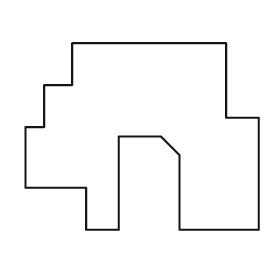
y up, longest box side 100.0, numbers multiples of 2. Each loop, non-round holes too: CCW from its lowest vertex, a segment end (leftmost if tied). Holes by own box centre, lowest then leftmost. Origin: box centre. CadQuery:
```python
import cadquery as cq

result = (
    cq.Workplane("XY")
    .moveTo(-24.0, -40.0)
    .lineTo(-10.0, -40.0)
    .lineTo(-10.0, 0.0)
    .lineTo(8.0, 0.0)
    .lineTo(16.0, -8.0)
    .lineTo(16.0, -40.0)
    .lineTo(50.0, -40.0)
    .lineTo(50.0, 8.0)
    .lineTo(36.0, 8.0)
    .lineTo(36.0, 40.0)
    .lineTo(-30.0, 40.0)
    .lineTo(-30.0, 22.0)
    .lineTo(-42.0, 22.0)
    .lineTo(-42.0, 4.0)
    .lineTo(-50.0, 4.0)
    .lineTo(-50.0, -22.0)
    .lineTo(-24.0, -22.0)
    .close()
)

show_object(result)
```